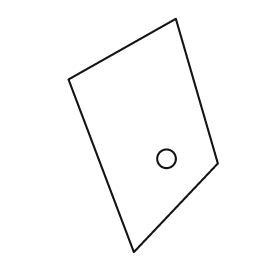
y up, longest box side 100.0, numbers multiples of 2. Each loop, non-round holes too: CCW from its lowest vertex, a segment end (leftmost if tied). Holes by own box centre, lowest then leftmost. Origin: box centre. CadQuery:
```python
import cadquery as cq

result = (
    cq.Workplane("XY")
    .moveTo(-4.0, -50.0)
    .lineTo(32.0, -12.0)
    .lineTo(14.0, 50.0)
    .lineTo(-32.0, 24.0)
    .close()
    .moveTo(10.0, -10.0)
    .circle(4.0)
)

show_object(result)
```